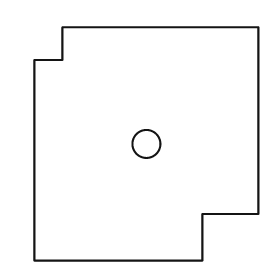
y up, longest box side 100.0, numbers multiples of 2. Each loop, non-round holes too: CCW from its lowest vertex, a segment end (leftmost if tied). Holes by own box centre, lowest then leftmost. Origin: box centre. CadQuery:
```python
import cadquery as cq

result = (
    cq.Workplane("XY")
    .moveTo(-48.0, -50.0)
    .lineTo(24.0, -50.0)
    .lineTo(24.0, -30.0)
    .lineTo(48.0, -30.0)
    .lineTo(48.0, 50.0)
    .lineTo(-36.0, 50.0)
    .lineTo(-36.0, 36.0)
    .lineTo(-48.0, 36.0)
    .close()
    .moveTo(0.0, 0.0)
    .circle(6.0)
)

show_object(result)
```